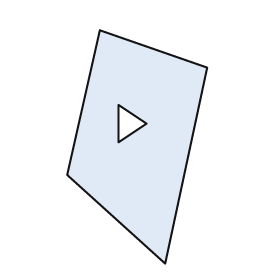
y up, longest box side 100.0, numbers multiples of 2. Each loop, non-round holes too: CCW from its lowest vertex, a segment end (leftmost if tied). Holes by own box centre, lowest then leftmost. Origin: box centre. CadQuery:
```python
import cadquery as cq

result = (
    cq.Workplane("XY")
    .moveTo(12.0, -50.0)
    .lineTo(30.0, 34.0)
    .lineTo(-16.0, 50.0)
    .lineTo(-30.0, -12.0)
    .close()
    .moveTo(-8.0, 2.0)
    .lineTo(4.0, 10.0)
    .lineTo(-8.0, 18.0)
    .close()
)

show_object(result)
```